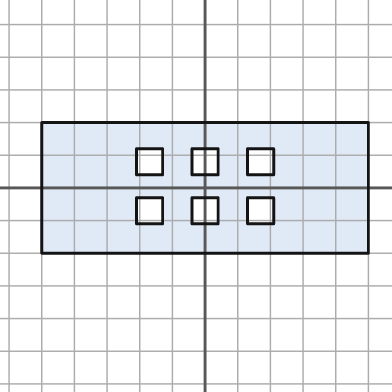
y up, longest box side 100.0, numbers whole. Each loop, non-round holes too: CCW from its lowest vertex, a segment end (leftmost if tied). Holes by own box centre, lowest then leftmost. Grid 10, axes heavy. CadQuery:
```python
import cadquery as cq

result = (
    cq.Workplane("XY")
    .moveTo(-50.0, -20.0)
    .lineTo(50.0, -20.0)
    .lineTo(50.0, 20.0)
    .lineTo(-50.0, 20.0)
    .close()
    .moveTo(-21.0, -11.0)
    .lineTo(-13.0, -11.0)
    .lineTo(-13.0, -3.0)
    .lineTo(-21.0, -3.0)
    .close()
    .moveTo(-4.0, -11.0)
    .lineTo(4.0, -11.0)
    .lineTo(4.0, -3.0)
    .lineTo(-4.0, -3.0)
    .close()
    .moveTo(13.0, -11.0)
    .lineTo(21.0, -11.0)
    .lineTo(21.0, -3.0)
    .lineTo(13.0, -3.0)
    .close()
    .moveTo(-21.0, 4.0)
    .lineTo(-13.0, 4.0)
    .lineTo(-13.0, 12.0)
    .lineTo(-21.0, 12.0)
    .close()
    .moveTo(-4.0, 4.0)
    .lineTo(4.0, 4.0)
    .lineTo(4.0, 12.0)
    .lineTo(-4.0, 12.0)
    .close()
    .moveTo(13.0, 4.0)
    .lineTo(21.0, 4.0)
    .lineTo(21.0, 12.0)
    .lineTo(13.0, 12.0)
    .close()
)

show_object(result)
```